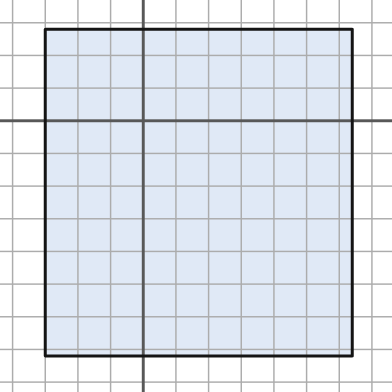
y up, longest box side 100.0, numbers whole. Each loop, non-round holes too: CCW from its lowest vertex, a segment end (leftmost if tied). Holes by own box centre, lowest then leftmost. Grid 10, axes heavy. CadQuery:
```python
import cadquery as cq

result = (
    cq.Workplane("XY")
    .moveTo(-30.0, -72.0)
    .lineTo(64.0, -72.0)
    .lineTo(64.0, 28.0)
    .lineTo(-30.0, 28.0)
    .close()
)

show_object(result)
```